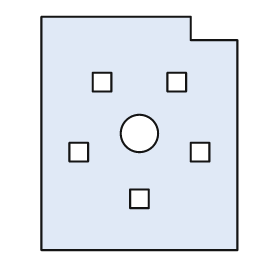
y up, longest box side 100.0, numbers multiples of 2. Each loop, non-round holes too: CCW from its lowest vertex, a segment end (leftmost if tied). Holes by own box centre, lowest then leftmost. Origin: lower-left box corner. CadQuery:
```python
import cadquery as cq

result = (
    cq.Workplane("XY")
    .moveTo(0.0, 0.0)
    .lineTo(84.0, 0.0)
    .lineTo(84.0, 90.0)
    .lineTo(64.0, 90.0)
    .lineTo(64.0, 100.0)
    .lineTo(0.0, 100.0)
    .close()
    .moveTo(38.0, 18.0)
    .lineTo(46.0, 18.0)
    .lineTo(46.0, 26.0)
    .lineTo(38.0, 26.0)
    .close()
    .moveTo(12.0, 38.0)
    .lineTo(20.0, 38.0)
    .lineTo(20.0, 46.0)
    .lineTo(12.0, 46.0)
    .close()
    .moveTo(64.0, 38.0)
    .lineTo(72.0, 38.0)
    .lineTo(72.0, 46.0)
    .lineTo(64.0, 46.0)
    .close()
    .moveTo(42.0, 50.0)
    .circle(8.0)
    .moveTo(22.0, 68.0)
    .lineTo(30.0, 68.0)
    .lineTo(30.0, 76.0)
    .lineTo(22.0, 76.0)
    .close()
    .moveTo(54.0, 68.0)
    .lineTo(62.0, 68.0)
    .lineTo(62.0, 76.0)
    .lineTo(54.0, 76.0)
    .close()
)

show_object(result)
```